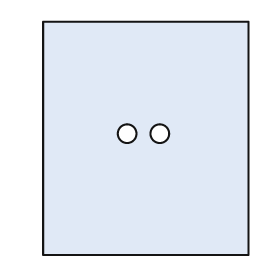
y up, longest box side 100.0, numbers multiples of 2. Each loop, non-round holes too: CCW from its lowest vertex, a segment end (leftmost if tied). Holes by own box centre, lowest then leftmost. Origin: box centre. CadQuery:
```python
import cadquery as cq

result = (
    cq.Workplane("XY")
    .moveTo(-44.0, -50.0)
    .lineTo(44.0, -50.0)
    .lineTo(44.0, 50.0)
    .lineTo(-44.0, 50.0)
    .close()
    .moveTo(-8.0, 2.0)
    .circle(4.0)
    .moveTo(6.0, 2.0)
    .circle(4.0)
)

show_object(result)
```